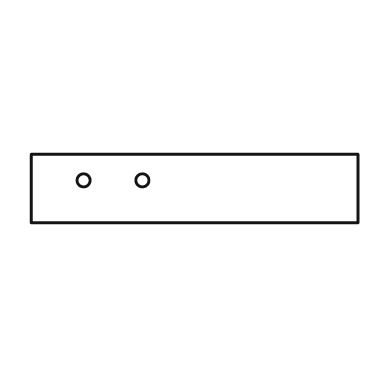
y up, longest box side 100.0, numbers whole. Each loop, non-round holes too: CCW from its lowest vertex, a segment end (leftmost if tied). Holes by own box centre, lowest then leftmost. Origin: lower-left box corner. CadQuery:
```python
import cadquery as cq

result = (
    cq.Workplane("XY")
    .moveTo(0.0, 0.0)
    .lineTo(100.0, 0.0)
    .lineTo(100.0, 21.0)
    .lineTo(0.0, 21.0)
    .close()
    .moveTo(16.0, 13.0)
    .circle(2.0)
    .moveTo(34.0, 13.0)
    .circle(2.0)
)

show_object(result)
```